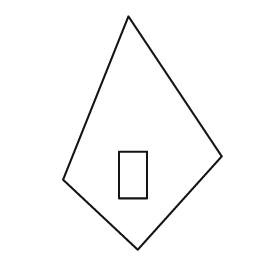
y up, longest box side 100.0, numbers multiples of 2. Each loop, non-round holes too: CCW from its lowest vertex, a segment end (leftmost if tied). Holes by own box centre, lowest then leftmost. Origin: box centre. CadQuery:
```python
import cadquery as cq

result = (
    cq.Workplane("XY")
    .moveTo(-2.0, -50.0)
    .lineTo(34.0, -10.0)
    .lineTo(-6.0, 50.0)
    .lineTo(-34.0, -20.0)
    .close()
    .moveTo(-10.0, -28.0)
    .lineTo(2.0, -28.0)
    .lineTo(2.0, -8.0)
    .lineTo(-10.0, -8.0)
    .close()
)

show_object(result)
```